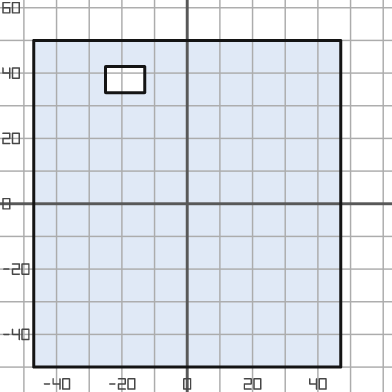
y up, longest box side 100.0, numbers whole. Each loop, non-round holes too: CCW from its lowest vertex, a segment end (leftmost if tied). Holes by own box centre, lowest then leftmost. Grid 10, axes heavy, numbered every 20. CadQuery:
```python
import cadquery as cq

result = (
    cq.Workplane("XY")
    .moveTo(-47.0, -50.0)
    .lineTo(47.0, -50.0)
    .lineTo(47.0, 50.0)
    .lineTo(-47.0, 50.0)
    .close()
    .moveTo(-25.0, 34.0)
    .lineTo(-13.0, 34.0)
    .lineTo(-13.0, 42.0)
    .lineTo(-25.0, 42.0)
    .close()
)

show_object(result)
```